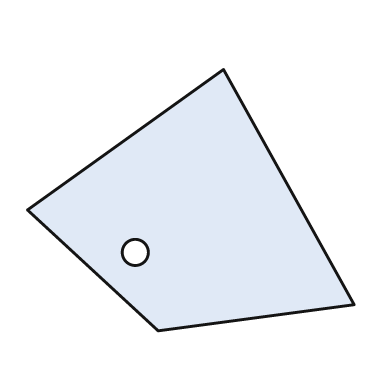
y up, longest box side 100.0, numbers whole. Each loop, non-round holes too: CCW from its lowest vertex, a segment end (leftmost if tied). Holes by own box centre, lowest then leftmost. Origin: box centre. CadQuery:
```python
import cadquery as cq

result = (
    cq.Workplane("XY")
    .moveTo(-10.0, -40.0)
    .lineTo(50.0, -32.0)
    .lineTo(10.0, 40.0)
    .lineTo(-50.0, -3.0)
    .close()
    .moveTo(-17.0, -16.0)
    .circle(4.0)
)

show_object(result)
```